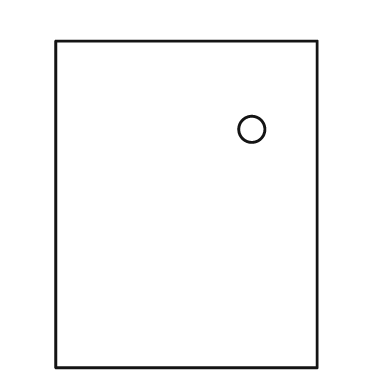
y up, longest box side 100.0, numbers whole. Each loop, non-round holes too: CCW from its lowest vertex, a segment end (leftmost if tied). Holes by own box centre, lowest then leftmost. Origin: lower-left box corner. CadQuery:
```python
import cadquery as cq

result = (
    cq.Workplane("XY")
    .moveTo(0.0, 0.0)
    .lineTo(80.0, 0.0)
    .lineTo(80.0, 100.0)
    .lineTo(0.0, 100.0)
    .close()
    .moveTo(60.0, 73.0)
    .circle(4.0)
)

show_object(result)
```